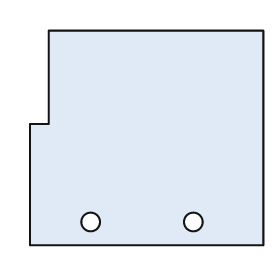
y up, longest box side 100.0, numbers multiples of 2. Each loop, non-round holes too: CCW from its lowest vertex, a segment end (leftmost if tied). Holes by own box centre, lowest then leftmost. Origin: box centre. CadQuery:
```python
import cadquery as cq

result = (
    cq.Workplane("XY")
    .moveTo(-50.0, -46.0)
    .lineTo(50.0, -46.0)
    .lineTo(50.0, 46.0)
    .lineTo(-42.0, 46.0)
    .lineTo(-42.0, 6.0)
    .lineTo(-50.0, 6.0)
    .close()
    .moveTo(-24.0, -36.0)
    .circle(4.0)
    .moveTo(20.0, -36.0)
    .circle(4.0)
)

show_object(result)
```